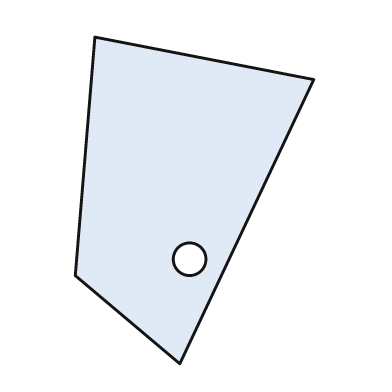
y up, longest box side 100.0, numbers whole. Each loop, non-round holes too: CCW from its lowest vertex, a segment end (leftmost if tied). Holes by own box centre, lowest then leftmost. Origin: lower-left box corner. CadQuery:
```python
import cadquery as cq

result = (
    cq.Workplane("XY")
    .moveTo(32.0, 0.0)
    .lineTo(73.0, 87.0)
    .lineTo(6.0, 100.0)
    .lineTo(0.0, 27.0)
    .close()
    .moveTo(35.0, 32.0)
    .circle(5.0)
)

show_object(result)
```